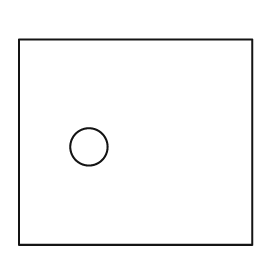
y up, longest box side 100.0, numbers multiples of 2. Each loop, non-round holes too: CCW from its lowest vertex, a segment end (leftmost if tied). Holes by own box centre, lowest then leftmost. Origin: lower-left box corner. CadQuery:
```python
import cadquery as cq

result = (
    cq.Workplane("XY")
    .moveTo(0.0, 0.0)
    .lineTo(100.0, 0.0)
    .lineTo(100.0, 88.0)
    .lineTo(0.0, 88.0)
    .close()
    .moveTo(30.0, 42.0)
    .circle(8.0)
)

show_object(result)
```